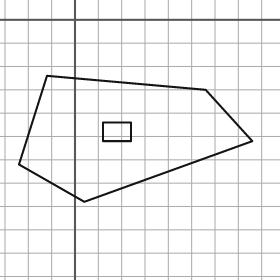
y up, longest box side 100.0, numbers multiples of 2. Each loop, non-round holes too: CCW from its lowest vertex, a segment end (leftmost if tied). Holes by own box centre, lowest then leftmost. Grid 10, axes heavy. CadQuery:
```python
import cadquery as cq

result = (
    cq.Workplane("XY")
    .moveTo(4.0, -78.0)
    .lineTo(76.0, -52.0)
    .lineTo(56.0, -30.0)
    .lineTo(-12.0, -24.0)
    .lineTo(-24.0, -62.0)
    .close()
    .moveTo(12.0, -52.0)
    .lineTo(24.0, -52.0)
    .lineTo(24.0, -44.0)
    .lineTo(12.0, -44.0)
    .close()
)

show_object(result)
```